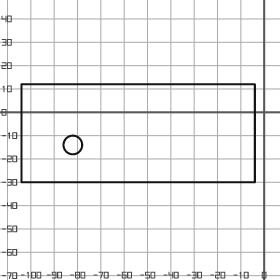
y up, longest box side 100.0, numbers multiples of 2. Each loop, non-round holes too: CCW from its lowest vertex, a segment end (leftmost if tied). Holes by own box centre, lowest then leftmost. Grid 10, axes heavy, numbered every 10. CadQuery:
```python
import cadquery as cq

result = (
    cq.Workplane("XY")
    .moveTo(-104.0, -30.0)
    .lineTo(-4.0, -30.0)
    .lineTo(-4.0, 12.0)
    .lineTo(-104.0, 12.0)
    .close()
    .moveTo(-82.0, -14.0)
    .circle(4.0)
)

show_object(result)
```